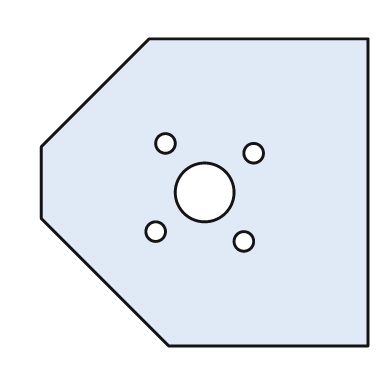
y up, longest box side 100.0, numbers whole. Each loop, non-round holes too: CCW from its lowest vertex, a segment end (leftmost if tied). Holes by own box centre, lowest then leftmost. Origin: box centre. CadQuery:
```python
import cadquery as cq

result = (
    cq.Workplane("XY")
    .moveTo(-11.0, -47.0)
    .lineTo(50.0, -47.0)
    .lineTo(50.0, 47.0)
    .lineTo(-17.0, 47.0)
    .lineTo(-50.0, 14.0)
    .lineTo(-50.0, -8.0)
    .close()
    .moveTo(12.0, -15.0)
    .circle(3.0)
    .moveTo(-15.0, -12.0)
    .circle(3.0)
    .moveTo(0.0, 0.0)
    .circle(9.0)
    .moveTo(15.0, 12.0)
    .circle(3.0)
    .moveTo(-12.0, 15.0)
    .circle(3.0)
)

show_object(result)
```